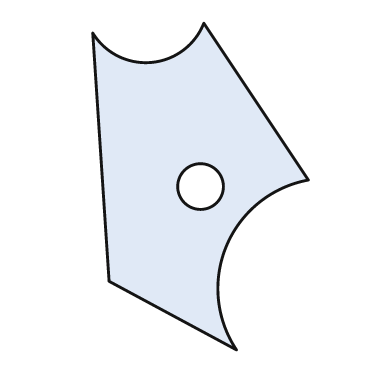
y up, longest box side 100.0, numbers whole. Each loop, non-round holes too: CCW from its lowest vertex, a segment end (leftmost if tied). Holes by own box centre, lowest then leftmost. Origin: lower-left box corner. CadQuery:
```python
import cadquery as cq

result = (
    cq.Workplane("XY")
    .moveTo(44.0, 0.0)
    .threePointArc((41.0, 32.0), (66.0, 52.0))
    .lineTo(34.0, 100.0)
    .threePointArc((18.0, 88.0), (0.0, 97.0))
    .lineTo(5.0, 21.0)
    .close()
    .moveTo(33.0, 50.0)
    .circle(7.0)
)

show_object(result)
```